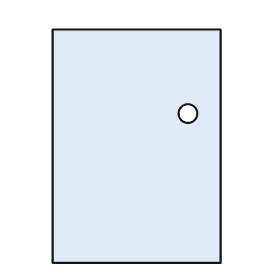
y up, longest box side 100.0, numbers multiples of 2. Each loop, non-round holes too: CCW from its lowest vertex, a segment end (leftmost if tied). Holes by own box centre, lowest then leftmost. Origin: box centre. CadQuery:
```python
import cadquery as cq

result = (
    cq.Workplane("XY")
    .moveTo(-36.0, -50.0)
    .lineTo(36.0, -50.0)
    .lineTo(36.0, 50.0)
    .lineTo(-36.0, 50.0)
    .close()
    .moveTo(22.0, 14.0)
    .circle(4.0)
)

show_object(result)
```